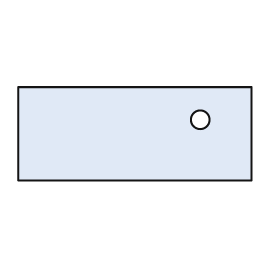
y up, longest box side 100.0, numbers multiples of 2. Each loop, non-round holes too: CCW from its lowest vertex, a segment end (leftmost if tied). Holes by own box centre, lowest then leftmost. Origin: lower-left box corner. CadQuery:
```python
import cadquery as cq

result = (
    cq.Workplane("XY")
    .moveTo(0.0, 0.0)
    .lineTo(100.0, 0.0)
    .lineTo(100.0, 40.0)
    .lineTo(0.0, 40.0)
    .close()
    .moveTo(78.0, 26.0)
    .circle(4.0)
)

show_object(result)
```